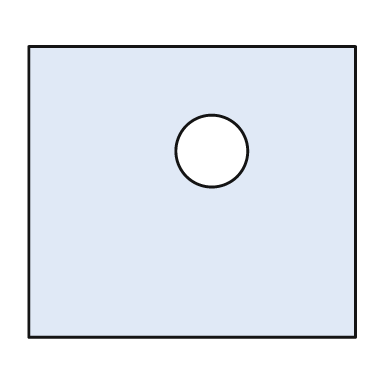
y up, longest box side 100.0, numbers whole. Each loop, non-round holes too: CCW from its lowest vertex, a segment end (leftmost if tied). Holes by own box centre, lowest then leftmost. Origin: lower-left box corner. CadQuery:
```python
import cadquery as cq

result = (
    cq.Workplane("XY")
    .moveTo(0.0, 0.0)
    .lineTo(100.0, 0.0)
    .lineTo(100.0, 89.0)
    .lineTo(0.0, 89.0)
    .close()
    .moveTo(56.0, 57.0)
    .circle(11.0)
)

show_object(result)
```